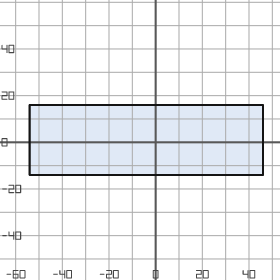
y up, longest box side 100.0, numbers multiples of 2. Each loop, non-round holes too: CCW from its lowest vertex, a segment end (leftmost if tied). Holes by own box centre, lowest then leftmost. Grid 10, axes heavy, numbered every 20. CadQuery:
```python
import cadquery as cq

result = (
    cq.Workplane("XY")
    .moveTo(-54.0, -14.0)
    .lineTo(46.0, -14.0)
    .lineTo(46.0, 16.0)
    .lineTo(-54.0, 16.0)
    .close()
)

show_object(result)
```